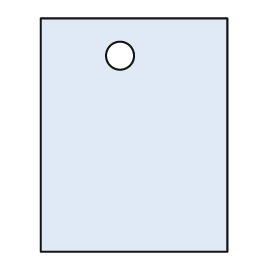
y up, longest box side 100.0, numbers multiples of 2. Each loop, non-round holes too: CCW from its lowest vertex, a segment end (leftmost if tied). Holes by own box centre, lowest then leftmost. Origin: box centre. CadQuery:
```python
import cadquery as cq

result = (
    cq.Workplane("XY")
    .moveTo(-40.0, -50.0)
    .lineTo(40.0, -50.0)
    .lineTo(40.0, 50.0)
    .lineTo(-40.0, 50.0)
    .close()
    .moveTo(-6.0, 34.0)
    .circle(6.0)
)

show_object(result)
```